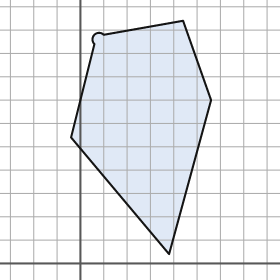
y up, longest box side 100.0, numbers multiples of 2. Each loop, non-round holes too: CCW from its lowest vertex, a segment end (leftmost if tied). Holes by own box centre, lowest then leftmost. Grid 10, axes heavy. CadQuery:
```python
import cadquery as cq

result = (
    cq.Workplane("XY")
    .moveTo(38.0, 4.0)
    .lineTo(56.0, 70.0)
    .lineTo(44.0, 104.0)
    .lineTo(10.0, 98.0)
    .threePointArc((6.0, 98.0), (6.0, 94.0))
    .lineTo(-4.0, 54.0)
    .close()
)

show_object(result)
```